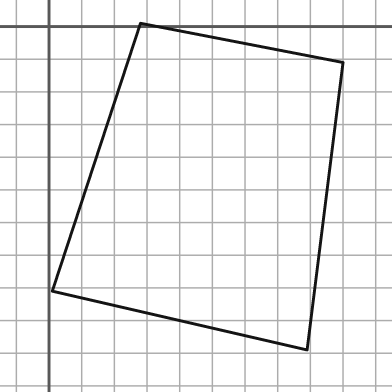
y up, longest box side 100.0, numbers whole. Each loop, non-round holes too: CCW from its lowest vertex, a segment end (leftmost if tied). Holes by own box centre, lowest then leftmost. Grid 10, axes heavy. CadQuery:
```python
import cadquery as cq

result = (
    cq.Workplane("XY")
    .moveTo(79.0, -99.0)
    .lineTo(90.0, -11.0)
    .lineTo(28.0, 1.0)
    .lineTo(1.0, -81.0)
    .close()
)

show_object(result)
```